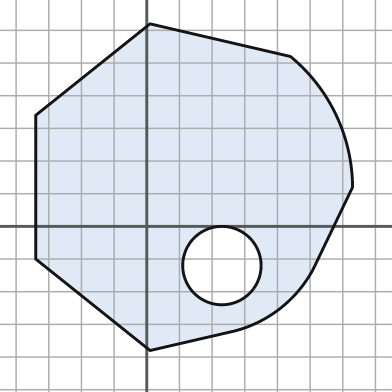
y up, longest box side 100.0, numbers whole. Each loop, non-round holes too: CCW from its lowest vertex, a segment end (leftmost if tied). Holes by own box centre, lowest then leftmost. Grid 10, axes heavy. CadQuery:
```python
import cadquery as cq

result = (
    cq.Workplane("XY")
    .moveTo(1.0, -38.0)
    .lineTo(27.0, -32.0)
    .threePointArc((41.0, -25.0), (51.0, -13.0))
    .lineTo(63.0, 12.0)
    .threePointArc((58.0, 34.0), (44.0, 52.0))
    .lineTo(1.0, 62.0)
    .lineTo(-34.0, 34.0)
    .lineTo(-34.0, -10.0)
    .close()
    .moveTo(23.0, -12.0)
    .circle(12.0)
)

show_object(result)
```